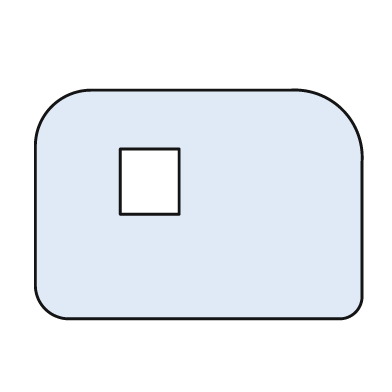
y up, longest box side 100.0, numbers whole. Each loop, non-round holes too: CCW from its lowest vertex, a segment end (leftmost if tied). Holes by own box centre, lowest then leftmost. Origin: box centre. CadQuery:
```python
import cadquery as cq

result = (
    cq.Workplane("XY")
    .moveTo(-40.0, -35.0)
    .lineTo(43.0, -35.0)
    .threePointArc((48.0, -33.0), (50.0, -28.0))
    .lineTo(50.0, 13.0)
    .threePointArc((44.0, 29.0), (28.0, 35.0))
    .lineTo(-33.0, 35.0)
    .threePointArc((-45.0, 30.0), (-50.0, 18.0))
    .lineTo(-50.0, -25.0)
    .threePointArc((-47.0, -32.0), (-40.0, -35.0))
    .close()
    .moveTo(-24.0, -3.0)
    .lineTo(-6.0, -3.0)
    .lineTo(-6.0, 17.0)
    .lineTo(-24.0, 17.0)
    .close()
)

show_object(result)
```